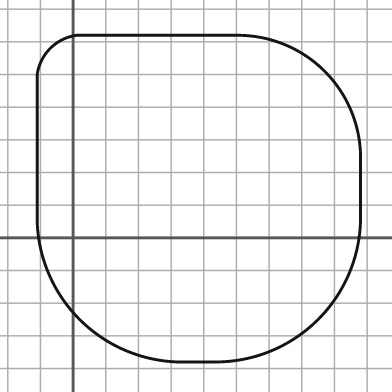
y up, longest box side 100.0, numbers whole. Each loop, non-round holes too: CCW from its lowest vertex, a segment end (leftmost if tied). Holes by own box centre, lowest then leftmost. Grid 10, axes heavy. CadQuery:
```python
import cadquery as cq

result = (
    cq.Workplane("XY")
    .moveTo(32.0, -38.0)
    .lineTo(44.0, -38.0)
    .threePointArc((75.0, -25.0), (88.0, 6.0))
    .lineTo(88.0, 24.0)
    .threePointArc((77.0, 51.0), (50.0, 62.0))
    .lineTo(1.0, 62.0)
    .threePointArc((-7.0, 58.0), (-11.0, 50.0))
    .lineTo(-11.0, 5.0)
    .threePointArc((2.0, -25.0), (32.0, -38.0))
    .close()
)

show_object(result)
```